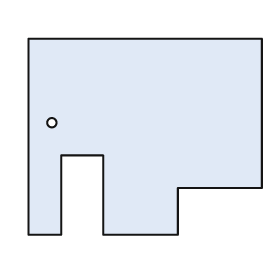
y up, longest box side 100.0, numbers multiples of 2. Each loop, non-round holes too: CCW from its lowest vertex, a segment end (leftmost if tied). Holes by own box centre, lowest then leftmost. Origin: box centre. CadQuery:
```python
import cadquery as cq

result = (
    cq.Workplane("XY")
    .moveTo(-50.0, -42.0)
    .lineTo(-36.0, -42.0)
    .lineTo(-36.0, -8.0)
    .lineTo(-18.0, -8.0)
    .lineTo(-18.0, -42.0)
    .lineTo(14.0, -42.0)
    .lineTo(14.0, -22.0)
    .lineTo(50.0, -22.0)
    .lineTo(50.0, 42.0)
    .lineTo(-50.0, 42.0)
    .close()
    .moveTo(-40.0, 6.0)
    .circle(2.0)
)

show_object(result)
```